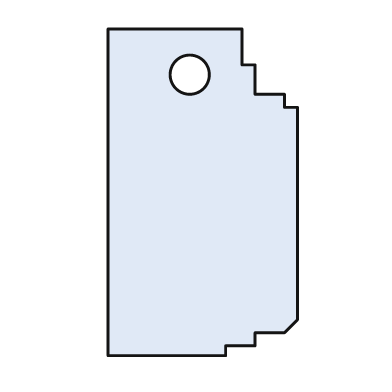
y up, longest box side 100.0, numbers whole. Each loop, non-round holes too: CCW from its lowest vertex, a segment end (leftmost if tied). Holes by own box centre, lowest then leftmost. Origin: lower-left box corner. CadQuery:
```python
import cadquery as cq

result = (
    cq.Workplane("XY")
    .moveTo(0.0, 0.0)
    .lineTo(36.0, 0.0)
    .lineTo(36.0, 3.0)
    .lineTo(45.0, 3.0)
    .lineTo(45.0, 7.0)
    .lineTo(54.0, 7.0)
    .lineTo(58.0, 11.0)
    .lineTo(58.0, 76.0)
    .lineTo(54.0, 76.0)
    .lineTo(54.0, 80.0)
    .lineTo(45.0, 80.0)
    .lineTo(45.0, 89.0)
    .lineTo(41.0, 89.0)
    .lineTo(41.0, 100.0)
    .lineTo(0.0, 100.0)
    .close()
    .moveTo(25.0, 86.0)
    .circle(6.0)
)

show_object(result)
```